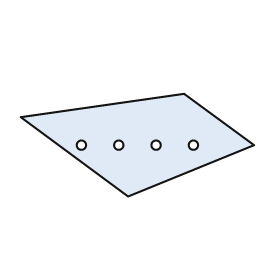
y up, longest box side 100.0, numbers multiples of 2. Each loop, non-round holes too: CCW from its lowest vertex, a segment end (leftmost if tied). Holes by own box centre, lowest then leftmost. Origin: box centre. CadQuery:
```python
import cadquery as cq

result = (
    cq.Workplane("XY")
    .moveTo(-4.0, -22.0)
    .lineTo(50.0, 0.0)
    .lineTo(20.0, 22.0)
    .lineTo(-50.0, 12.0)
    .close()
    .moveTo(-24.0, 0.0)
    .circle(2.0)
    .moveTo(-8.0, 0.0)
    .circle(2.0)
    .moveTo(8.0, 0.0)
    .circle(2.0)
    .moveTo(24.0, 0.0)
    .circle(2.0)
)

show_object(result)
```